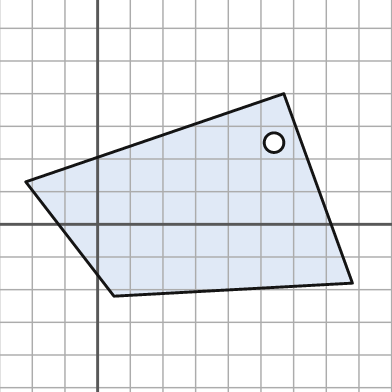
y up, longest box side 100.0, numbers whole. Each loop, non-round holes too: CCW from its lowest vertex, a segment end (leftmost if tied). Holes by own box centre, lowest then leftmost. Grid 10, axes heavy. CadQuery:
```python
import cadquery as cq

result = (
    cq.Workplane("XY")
    .moveTo(5.0, -22.0)
    .lineTo(78.0, -18.0)
    .lineTo(57.0, 40.0)
    .lineTo(-22.0, 13.0)
    .close()
    .moveTo(54.0, 25.0)
    .circle(3.0)
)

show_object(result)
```